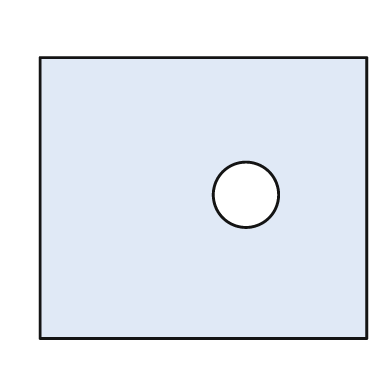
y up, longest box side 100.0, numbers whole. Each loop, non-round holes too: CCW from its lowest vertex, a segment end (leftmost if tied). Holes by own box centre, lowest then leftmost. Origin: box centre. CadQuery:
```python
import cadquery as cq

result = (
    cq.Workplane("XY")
    .moveTo(-50.0, -43.0)
    .lineTo(50.0, -43.0)
    .lineTo(50.0, 43.0)
    .lineTo(-50.0, 43.0)
    .close()
    .moveTo(13.0, 1.0)
    .circle(10.0)
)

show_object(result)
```